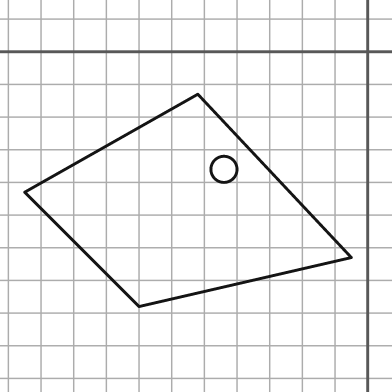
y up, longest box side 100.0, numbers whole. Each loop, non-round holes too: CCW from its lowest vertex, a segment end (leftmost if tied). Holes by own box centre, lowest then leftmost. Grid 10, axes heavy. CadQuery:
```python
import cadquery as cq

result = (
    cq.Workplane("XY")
    .moveTo(-70.0, -78.0)
    .lineTo(-5.0, -63.0)
    .lineTo(-52.0, -13.0)
    .lineTo(-105.0, -43.0)
    .close()
    .moveTo(-44.0, -36.0)
    .circle(4.0)
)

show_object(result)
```